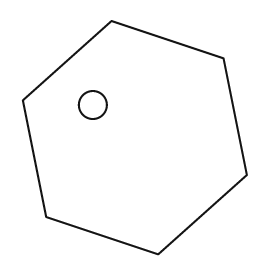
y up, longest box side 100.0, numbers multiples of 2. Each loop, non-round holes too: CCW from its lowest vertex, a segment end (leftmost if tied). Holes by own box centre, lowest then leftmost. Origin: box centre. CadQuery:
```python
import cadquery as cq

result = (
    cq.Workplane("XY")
    .moveTo(10.0, -50.0)
    .lineTo(48.0, -16.0)
    .lineTo(38.0, 34.0)
    .lineTo(-10.0, 50.0)
    .lineTo(-48.0, 16.0)
    .lineTo(-38.0, -34.0)
    .close()
    .moveTo(-18.0, 14.0)
    .circle(6.0)
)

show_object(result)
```